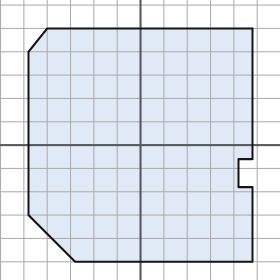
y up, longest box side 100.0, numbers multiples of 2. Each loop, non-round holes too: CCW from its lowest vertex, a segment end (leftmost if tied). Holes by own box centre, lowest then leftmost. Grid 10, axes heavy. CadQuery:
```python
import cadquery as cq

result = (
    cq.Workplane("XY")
    .moveTo(-28.0, -50.0)
    .lineTo(48.0, -50.0)
    .lineTo(48.0, -18.0)
    .lineTo(42.0, -18.0)
    .lineTo(42.0, -6.0)
    .lineTo(48.0, -6.0)
    .lineTo(48.0, 50.0)
    .lineTo(-40.0, 50.0)
    .lineTo(-48.0, 40.0)
    .lineTo(-48.0, -30.0)
    .close()
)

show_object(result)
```